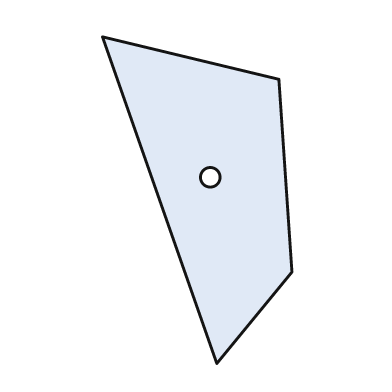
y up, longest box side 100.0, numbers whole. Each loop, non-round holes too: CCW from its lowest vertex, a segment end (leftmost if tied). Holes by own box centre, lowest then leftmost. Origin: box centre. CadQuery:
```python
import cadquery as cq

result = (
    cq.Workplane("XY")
    .moveTo(6.0, -50.0)
    .lineTo(29.0, -22.0)
    .lineTo(25.0, 37.0)
    .lineTo(-29.0, 50.0)
    .close()
    .moveTo(4.0, 7.0)
    .circle(3.0)
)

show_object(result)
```